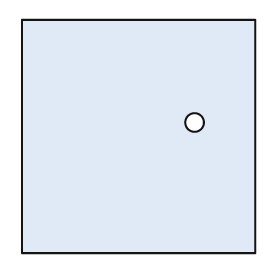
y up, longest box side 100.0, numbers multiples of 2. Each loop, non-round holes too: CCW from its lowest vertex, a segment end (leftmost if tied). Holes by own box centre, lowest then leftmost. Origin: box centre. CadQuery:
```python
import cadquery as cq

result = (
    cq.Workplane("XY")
    .moveTo(-50.0, -50.0)
    .lineTo(50.0, -50.0)
    .lineTo(50.0, 50.0)
    .lineTo(-50.0, 50.0)
    .close()
    .moveTo(24.0, 6.0)
    .circle(4.0)
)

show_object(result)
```